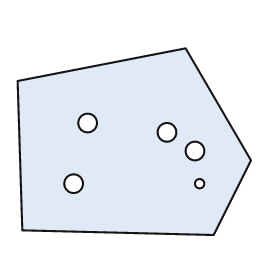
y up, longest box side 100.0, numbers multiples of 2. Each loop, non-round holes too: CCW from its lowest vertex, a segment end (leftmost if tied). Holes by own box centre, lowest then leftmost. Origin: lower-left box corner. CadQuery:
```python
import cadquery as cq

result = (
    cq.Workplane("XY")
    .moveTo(84.0, 0.0)
    .lineTo(100.0, 32.0)
    .lineTo(72.0, 80.0)
    .lineTo(0.0, 66.0)
    .lineTo(2.0, 2.0)
    .close()
    .moveTo(24.0, 22.0)
    .circle(4.0)
    .moveTo(78.0, 22.0)
    .circle(2.0)
    .moveTo(76.0, 36.0)
    .circle(4.0)
    .moveTo(64.0, 44.0)
    .circle(4.0)
    .moveTo(30.0, 48.0)
    .circle(4.0)
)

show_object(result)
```